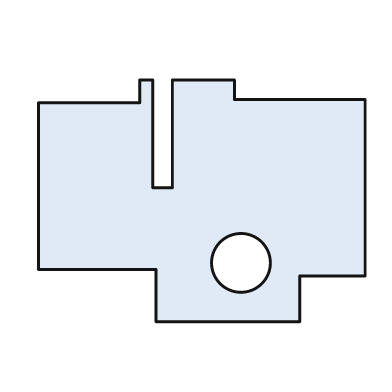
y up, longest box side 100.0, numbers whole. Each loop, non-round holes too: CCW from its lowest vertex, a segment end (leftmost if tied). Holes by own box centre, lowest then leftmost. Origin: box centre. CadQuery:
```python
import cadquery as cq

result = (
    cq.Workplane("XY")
    .moveTo(-14.0, -37.0)
    .lineTo(30.0, -37.0)
    .lineTo(30.0, -23.0)
    .lineTo(50.0, -23.0)
    .lineTo(50.0, 31.0)
    .lineTo(10.0, 31.0)
    .lineTo(10.0, 37.0)
    .lineTo(-9.0, 37.0)
    .lineTo(-9.0, 4.0)
    .lineTo(-15.0, 4.0)
    .lineTo(-15.0, 37.0)
    .lineTo(-19.0, 37.0)
    .lineTo(-19.0, 30.0)
    .lineTo(-50.0, 30.0)
    .lineTo(-50.0, -21.0)
    .lineTo(-14.0, -21.0)
    .close()
    .moveTo(12.0, -19.0)
    .circle(9.0)
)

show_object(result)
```